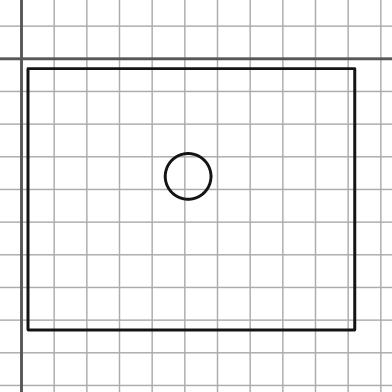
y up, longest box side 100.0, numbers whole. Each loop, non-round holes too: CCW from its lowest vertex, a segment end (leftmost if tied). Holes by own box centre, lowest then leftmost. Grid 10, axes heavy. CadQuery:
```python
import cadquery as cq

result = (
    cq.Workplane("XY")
    .moveTo(2.0, -83.0)
    .lineTo(102.0, -83.0)
    .lineTo(102.0, -3.0)
    .lineTo(2.0, -3.0)
    .close()
    .moveTo(51.0, -36.0)
    .circle(7.0)
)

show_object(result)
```